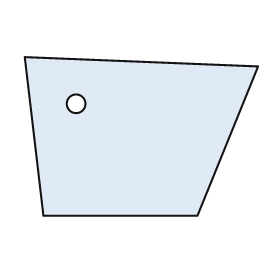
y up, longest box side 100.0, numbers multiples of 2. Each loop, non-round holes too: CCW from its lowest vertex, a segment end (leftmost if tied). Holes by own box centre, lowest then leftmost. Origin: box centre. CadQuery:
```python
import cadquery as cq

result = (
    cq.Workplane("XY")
    .moveTo(-42.0, -34.0)
    .lineTo(24.0, -34.0)
    .lineTo(50.0, 30.0)
    .lineTo(-50.0, 34.0)
    .close()
    .moveTo(-28.0, 14.0)
    .circle(4.0)
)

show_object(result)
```